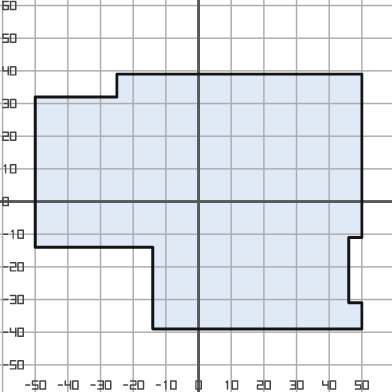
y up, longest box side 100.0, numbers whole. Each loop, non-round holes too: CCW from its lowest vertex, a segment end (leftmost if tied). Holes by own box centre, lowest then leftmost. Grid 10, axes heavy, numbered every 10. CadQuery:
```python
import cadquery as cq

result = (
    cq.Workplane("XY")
    .moveTo(-14.0, -39.0)
    .lineTo(50.0, -39.0)
    .lineTo(50.0, -31.0)
    .lineTo(46.0, -31.0)
    .lineTo(46.0, -11.0)
    .lineTo(50.0, -11.0)
    .lineTo(50.0, 39.0)
    .lineTo(-25.0, 39.0)
    .lineTo(-25.0, 32.0)
    .lineTo(-50.0, 32.0)
    .lineTo(-50.0, -14.0)
    .lineTo(-14.0, -14.0)
    .close()
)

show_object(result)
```